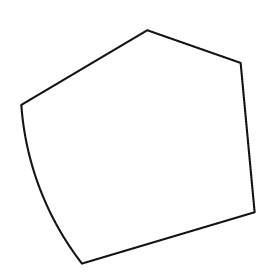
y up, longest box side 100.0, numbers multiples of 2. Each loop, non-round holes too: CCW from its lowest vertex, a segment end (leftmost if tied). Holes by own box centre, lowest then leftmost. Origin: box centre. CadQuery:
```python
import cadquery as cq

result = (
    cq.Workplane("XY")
    .moveTo(-24.0, -50.0)
    .lineTo(50.0, -28.0)
    .lineTo(44.0, 36.0)
    .lineTo(4.0, 50.0)
    .lineTo(-50.0, 18.0)
    .threePointArc((-42.0, -18.0), (-24.0, -50.0))
    .close()
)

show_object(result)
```